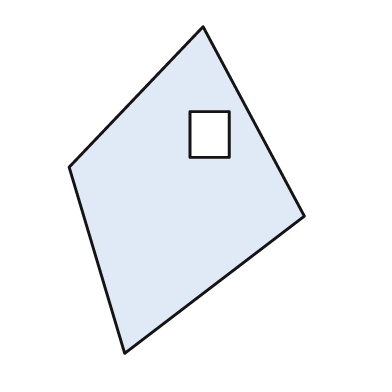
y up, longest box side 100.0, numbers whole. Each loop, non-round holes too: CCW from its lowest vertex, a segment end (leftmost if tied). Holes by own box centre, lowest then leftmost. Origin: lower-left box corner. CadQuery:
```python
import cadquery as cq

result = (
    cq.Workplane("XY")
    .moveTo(17.0, 0.0)
    .lineTo(72.0, 42.0)
    .lineTo(41.0, 100.0)
    .lineTo(0.0, 57.0)
    .close()
    .moveTo(37.0, 60.0)
    .lineTo(49.0, 60.0)
    .lineTo(49.0, 74.0)
    .lineTo(37.0, 74.0)
    .close()
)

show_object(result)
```